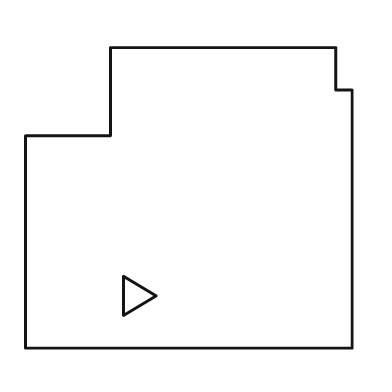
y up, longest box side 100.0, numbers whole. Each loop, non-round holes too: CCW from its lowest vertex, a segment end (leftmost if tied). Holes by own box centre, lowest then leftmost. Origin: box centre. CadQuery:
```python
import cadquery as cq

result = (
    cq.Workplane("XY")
    .moveTo(-50.0, -46.0)
    .lineTo(50.0, -46.0)
    .lineTo(50.0, 33.0)
    .lineTo(45.0, 33.0)
    .lineTo(45.0, 46.0)
    .lineTo(-24.0, 46.0)
    .lineTo(-24.0, 19.0)
    .lineTo(-50.0, 19.0)
    .close()
    .moveTo(-20.0, -36.0)
    .lineTo(-10.0, -30.0)
    .lineTo(-20.0, -24.0)
    .close()
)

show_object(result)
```